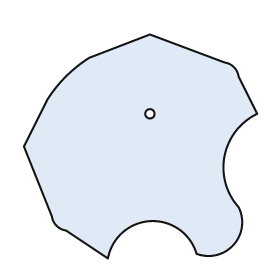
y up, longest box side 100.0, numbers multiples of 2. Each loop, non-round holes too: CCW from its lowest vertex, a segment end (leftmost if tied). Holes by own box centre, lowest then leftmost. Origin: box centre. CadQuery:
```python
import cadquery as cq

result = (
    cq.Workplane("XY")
    .moveTo(-14.0, -48.0)
    .threePointArc((4.0, -32.0), (24.0, -46.0))
    .threePointArc((40.0, -42.0), (42.0, -26.0))
    .threePointArc((36.0, -4.0), (50.0, 14.0))
    .lineTo(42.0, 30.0)
    .threePointArc((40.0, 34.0), (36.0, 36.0))
    .lineTo(4.0, 48.0)
    .lineTo(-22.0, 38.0)
    .threePointArc((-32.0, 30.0), (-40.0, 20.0))
    .lineTo(-50.0, 0.0)
    .lineTo(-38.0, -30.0)
    .threePointArc((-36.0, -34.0), (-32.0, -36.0))
    .close()
    .moveTo(4.0, 14.0)
    .circle(2.0)
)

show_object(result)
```